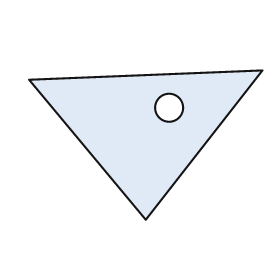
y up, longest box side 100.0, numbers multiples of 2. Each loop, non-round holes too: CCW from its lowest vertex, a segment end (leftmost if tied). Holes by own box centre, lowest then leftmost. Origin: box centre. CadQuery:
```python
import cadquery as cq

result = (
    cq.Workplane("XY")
    .moveTo(0.0, -32.0)
    .lineTo(50.0, 32.0)
    .lineTo(-50.0, 28.0)
    .close()
    .moveTo(10.0, 16.0)
    .circle(6.0)
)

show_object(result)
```